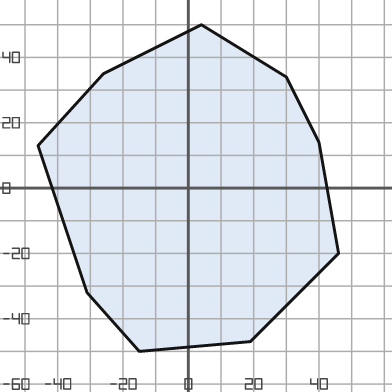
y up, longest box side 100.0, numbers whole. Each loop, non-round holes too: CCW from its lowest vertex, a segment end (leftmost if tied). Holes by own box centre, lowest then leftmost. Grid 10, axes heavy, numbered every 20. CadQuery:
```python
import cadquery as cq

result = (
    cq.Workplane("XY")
    .moveTo(-15.0, -50.0)
    .lineTo(19.0, -47.0)
    .lineTo(46.0, -20.0)
    .lineTo(40.0, 14.0)
    .lineTo(30.0, 34.0)
    .lineTo(4.0, 50.0)
    .lineTo(-26.0, 35.0)
    .lineTo(-46.0, 13.0)
    .lineTo(-31.0, -32.0)
    .close()
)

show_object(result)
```